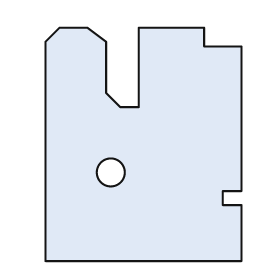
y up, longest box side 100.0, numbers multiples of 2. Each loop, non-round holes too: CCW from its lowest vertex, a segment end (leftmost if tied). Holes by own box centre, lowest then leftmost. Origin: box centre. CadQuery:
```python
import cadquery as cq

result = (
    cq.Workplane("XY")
    .moveTo(-42.0, -50.0)
    .lineTo(42.0, -50.0)
    .lineTo(42.0, -26.0)
    .lineTo(34.0, -26.0)
    .lineTo(34.0, -20.0)
    .lineTo(42.0, -20.0)
    .lineTo(42.0, 42.0)
    .lineTo(26.0, 42.0)
    .lineTo(26.0, 50.0)
    .lineTo(-2.0, 50.0)
    .lineTo(-2.0, 16.0)
    .lineTo(-10.0, 16.0)
    .lineTo(-16.0, 22.0)
    .lineTo(-16.0, 44.0)
    .lineTo(-24.0, 50.0)
    .lineTo(-36.0, 50.0)
    .lineTo(-42.0, 44.0)
    .close()
    .moveTo(-14.0, -12.0)
    .circle(6.0)
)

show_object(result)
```